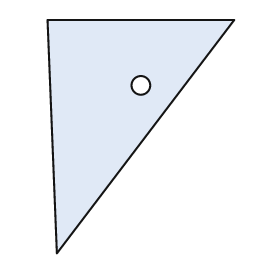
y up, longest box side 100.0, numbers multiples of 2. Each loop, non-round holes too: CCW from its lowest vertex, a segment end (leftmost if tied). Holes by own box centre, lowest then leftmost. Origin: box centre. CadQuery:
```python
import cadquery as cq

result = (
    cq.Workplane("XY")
    .moveTo(-36.0, -50.0)
    .lineTo(40.0, 50.0)
    .lineTo(-40.0, 50.0)
    .close()
    .moveTo(0.0, 22.0)
    .circle(4.0)
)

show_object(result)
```